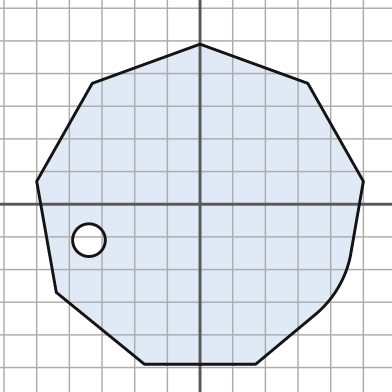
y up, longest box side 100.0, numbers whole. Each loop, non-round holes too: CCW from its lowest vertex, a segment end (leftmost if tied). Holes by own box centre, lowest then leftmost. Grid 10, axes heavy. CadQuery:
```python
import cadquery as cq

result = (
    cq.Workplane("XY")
    .moveTo(-17.0, -49.0)
    .lineTo(17.0, -49.0)
    .lineTo(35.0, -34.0)
    .threePointArc((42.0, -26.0), (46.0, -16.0))
    .lineTo(50.0, 7.0)
    .lineTo(33.0, 37.0)
    .lineTo(0.0, 49.0)
    .lineTo(-33.0, 37.0)
    .lineTo(-50.0, 7.0)
    .lineTo(-44.0, -27.0)
    .close()
    .moveTo(-34.0, -11.0)
    .circle(5.0)
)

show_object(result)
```